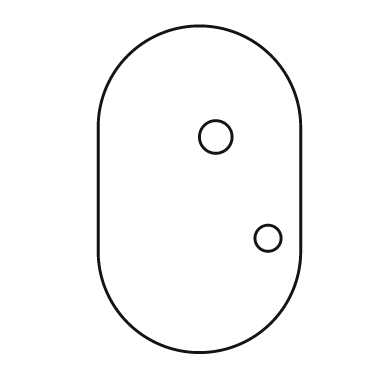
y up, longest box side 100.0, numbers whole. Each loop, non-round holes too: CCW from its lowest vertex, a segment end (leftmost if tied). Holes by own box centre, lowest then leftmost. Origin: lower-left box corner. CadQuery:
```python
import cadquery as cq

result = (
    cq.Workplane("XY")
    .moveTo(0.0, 31.0)
    .threePointArc((31.0, 0.0), (62.0, 31.0))
    .lineTo(62.0, 69.0)
    .threePointArc((31.0, 100.0), (0.0, 69.0))
    .close()
    .moveTo(52.0, 35.0)
    .circle(4.0)
    .moveTo(36.0, 66.0)
    .circle(5.0)
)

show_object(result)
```